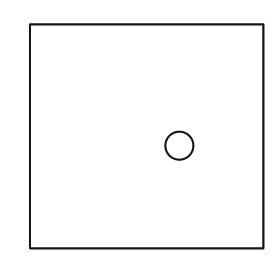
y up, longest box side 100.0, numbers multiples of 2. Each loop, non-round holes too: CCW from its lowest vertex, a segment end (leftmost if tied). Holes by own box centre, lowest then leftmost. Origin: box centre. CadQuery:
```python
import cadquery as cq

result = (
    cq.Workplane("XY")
    .moveTo(-50.0, -48.0)
    .lineTo(50.0, -48.0)
    .lineTo(50.0, 48.0)
    .lineTo(-50.0, 48.0)
    .close()
    .moveTo(14.0, -4.0)
    .circle(6.0)
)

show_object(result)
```